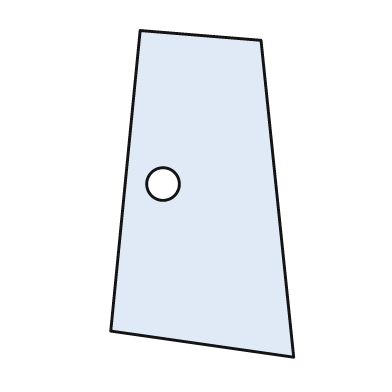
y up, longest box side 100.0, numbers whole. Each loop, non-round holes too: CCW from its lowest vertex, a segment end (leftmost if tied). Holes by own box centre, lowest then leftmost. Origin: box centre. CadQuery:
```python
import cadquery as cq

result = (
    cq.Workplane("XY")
    .moveTo(28.0, -50.0)
    .lineTo(18.0, 47.0)
    .lineTo(-19.0, 50.0)
    .lineTo(-28.0, -42.0)
    .close()
    .moveTo(-12.0, 3.0)
    .circle(5.0)
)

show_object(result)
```